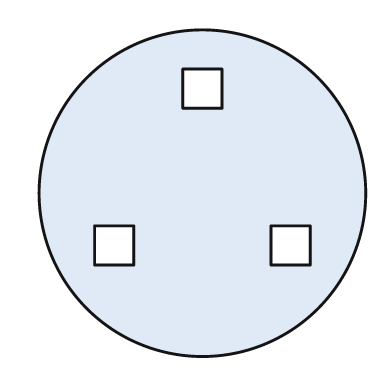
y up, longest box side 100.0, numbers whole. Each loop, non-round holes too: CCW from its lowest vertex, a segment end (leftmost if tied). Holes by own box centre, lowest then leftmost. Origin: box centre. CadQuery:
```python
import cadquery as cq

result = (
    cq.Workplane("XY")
    .moveTo(0.0, 0.0)
    .circle(50.0)
    .moveTo(-33.0, -22.0)
    .lineTo(-21.0, -22.0)
    .lineTo(-21.0, -10.0)
    .lineTo(-33.0, -10.0)
    .close()
    .moveTo(21.0, -22.0)
    .lineTo(33.0, -22.0)
    .lineTo(33.0, -10.0)
    .lineTo(21.0, -10.0)
    .close()
    .moveTo(-6.0, 26.0)
    .lineTo(6.0, 26.0)
    .lineTo(6.0, 38.0)
    .lineTo(-6.0, 38.0)
    .close()
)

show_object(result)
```